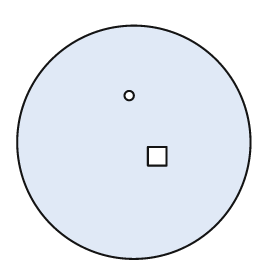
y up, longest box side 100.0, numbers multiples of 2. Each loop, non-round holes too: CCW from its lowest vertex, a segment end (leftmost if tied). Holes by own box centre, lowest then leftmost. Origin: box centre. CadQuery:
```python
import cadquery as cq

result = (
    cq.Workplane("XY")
    .moveTo(0.0, 0.0)
    .circle(50.0)
    .moveTo(6.0, -10.0)
    .lineTo(14.0, -10.0)
    .lineTo(14.0, -2.0)
    .lineTo(6.0, -2.0)
    .close()
    .moveTo(-2.0, 20.0)
    .circle(2.0)
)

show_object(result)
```